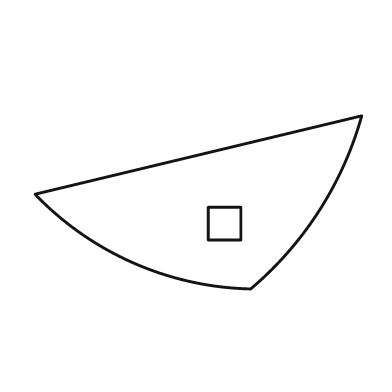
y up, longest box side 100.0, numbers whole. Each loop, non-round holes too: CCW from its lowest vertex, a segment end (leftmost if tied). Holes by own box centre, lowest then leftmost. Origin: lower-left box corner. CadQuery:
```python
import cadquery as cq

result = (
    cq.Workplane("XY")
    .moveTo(66.0, 0.0)
    .threePointArc((87.0, 24.0), (100.0, 53.0))
    .lineTo(0.0, 29.0)
    .threePointArc((30.0, 8.0), (66.0, 0.0))
    .close()
    .moveTo(53.0, 15.0)
    .lineTo(63.0, 15.0)
    .lineTo(63.0, 25.0)
    .lineTo(53.0, 25.0)
    .close()
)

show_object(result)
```